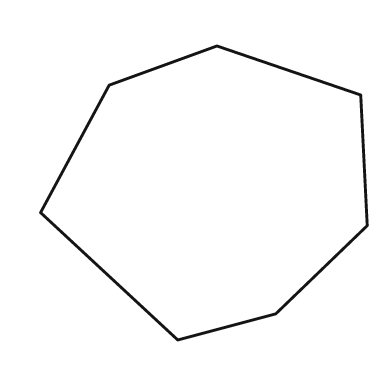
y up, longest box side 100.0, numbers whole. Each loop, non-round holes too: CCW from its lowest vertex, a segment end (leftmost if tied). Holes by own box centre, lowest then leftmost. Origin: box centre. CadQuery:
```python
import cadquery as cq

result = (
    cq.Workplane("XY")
    .moveTo(-8.0, -45.0)
    .lineTo(22.0, -37.0)
    .lineTo(50.0, -10.0)
    .lineTo(48.0, 30.0)
    .lineTo(4.0, 45.0)
    .lineTo(-29.0, 33.0)
    .lineTo(-50.0, -6.0)
    .close()
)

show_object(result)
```